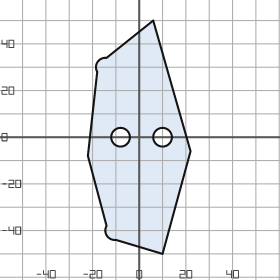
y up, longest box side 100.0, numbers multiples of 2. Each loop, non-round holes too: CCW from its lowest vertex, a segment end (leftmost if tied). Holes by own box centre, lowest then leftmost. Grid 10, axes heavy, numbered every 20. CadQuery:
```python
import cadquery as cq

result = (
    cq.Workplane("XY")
    .moveTo(10.0, -50.0)
    .lineTo(22.0, -6.0)
    .lineTo(6.0, 50.0)
    .lineTo(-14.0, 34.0)
    .threePointArc((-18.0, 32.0), (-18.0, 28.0))
    .lineTo(-22.0, -8.0)
    .lineTo(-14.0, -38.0)
    .threePointArc((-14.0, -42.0), (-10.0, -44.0))
    .close()
    .moveTo(-8.0, 0.0)
    .circle(4.0)
    .moveTo(10.0, 0.0)
    .circle(4.0)
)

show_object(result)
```